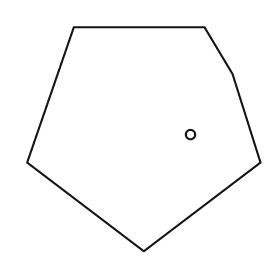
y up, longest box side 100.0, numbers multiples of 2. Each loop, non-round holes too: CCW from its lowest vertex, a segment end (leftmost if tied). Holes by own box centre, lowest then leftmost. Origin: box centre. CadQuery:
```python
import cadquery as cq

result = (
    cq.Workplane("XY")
    .moveTo(0.0, -48.0)
    .lineTo(50.0, -10.0)
    .lineTo(38.0, 28.0)
    .lineTo(26.0, 48.0)
    .lineTo(-30.0, 48.0)
    .lineTo(-50.0, -10.0)
    .close()
    .moveTo(20.0, 2.0)
    .circle(2.0)
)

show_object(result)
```